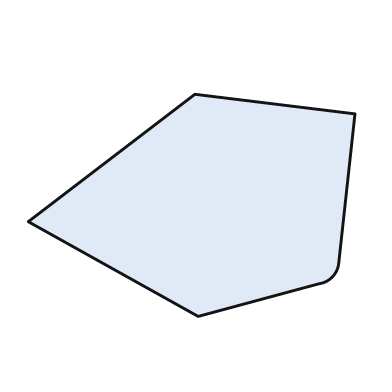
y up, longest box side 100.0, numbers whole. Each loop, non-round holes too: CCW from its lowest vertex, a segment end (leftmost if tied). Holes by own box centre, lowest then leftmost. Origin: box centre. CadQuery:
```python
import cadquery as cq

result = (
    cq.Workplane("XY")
    .moveTo(2.0, -34.0)
    .lineTo(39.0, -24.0)
    .threePointArc((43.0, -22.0), (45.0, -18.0))
    .lineTo(50.0, 28.0)
    .lineTo(1.0, 34.0)
    .lineTo(-50.0, -5.0)
    .close()
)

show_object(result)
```